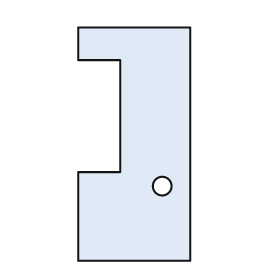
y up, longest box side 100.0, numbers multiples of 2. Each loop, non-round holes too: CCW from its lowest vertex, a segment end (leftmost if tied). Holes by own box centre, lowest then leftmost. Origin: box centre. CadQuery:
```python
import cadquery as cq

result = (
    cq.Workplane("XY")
    .moveTo(-24.0, -50.0)
    .lineTo(24.0, -50.0)
    .lineTo(24.0, 50.0)
    .lineTo(-24.0, 50.0)
    .lineTo(-24.0, 36.0)
    .lineTo(-6.0, 36.0)
    .lineTo(-6.0, -12.0)
    .lineTo(-24.0, -12.0)
    .close()
    .moveTo(12.0, -18.0)
    .circle(4.0)
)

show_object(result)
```